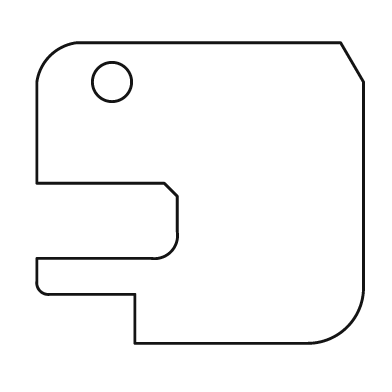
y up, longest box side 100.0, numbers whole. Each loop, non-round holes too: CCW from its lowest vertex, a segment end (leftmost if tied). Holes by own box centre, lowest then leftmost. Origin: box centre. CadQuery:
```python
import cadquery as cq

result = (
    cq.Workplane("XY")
    .moveTo(-20.0, -46.0)
    .lineTo(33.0, -46.0)
    .threePointArc((45.0, -41.0), (50.0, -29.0))
    .lineTo(50.0, 34.0)
    .lineTo(43.0, 46.0)
    .lineTo(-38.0, 46.0)
    .threePointArc((-46.0, 42.0), (-50.0, 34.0))
    .lineTo(-50.0, 3.0)
    .lineTo(-11.0, 3.0)
    .lineTo(-7.0, -1.0)
    .lineTo(-7.0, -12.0)
    .threePointArc((-9.0, -18.0), (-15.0, -20.0))
    .lineTo(-50.0, -20.0)
    .lineTo(-50.0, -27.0)
    .threePointArc((-49.0, -30.0), (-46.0, -31.0))
    .lineTo(-20.0, -31.0)
    .close()
    .moveTo(-27.0, 34.0)
    .circle(6.0)
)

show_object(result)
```